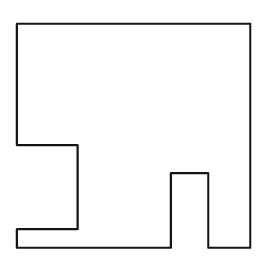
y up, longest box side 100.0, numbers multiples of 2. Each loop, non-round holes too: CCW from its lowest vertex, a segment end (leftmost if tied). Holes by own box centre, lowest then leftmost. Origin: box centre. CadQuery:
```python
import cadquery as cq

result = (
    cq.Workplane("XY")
    .moveTo(-50.0, -48.0)
    .lineTo(16.0, -48.0)
    .lineTo(16.0, -16.0)
    .lineTo(32.0, -16.0)
    .lineTo(32.0, -48.0)
    .lineTo(50.0, -48.0)
    .lineTo(50.0, 48.0)
    .lineTo(-50.0, 48.0)
    .lineTo(-50.0, -4.0)
    .lineTo(-24.0, -4.0)
    .lineTo(-24.0, -40.0)
    .lineTo(-50.0, -40.0)
    .close()
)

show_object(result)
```